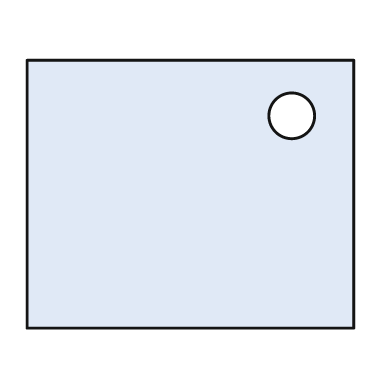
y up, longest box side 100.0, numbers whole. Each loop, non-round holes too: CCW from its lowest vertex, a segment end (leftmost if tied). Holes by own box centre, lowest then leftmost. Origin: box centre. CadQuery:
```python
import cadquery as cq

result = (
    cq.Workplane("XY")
    .moveTo(-50.0, -41.0)
    .lineTo(50.0, -41.0)
    .lineTo(50.0, 41.0)
    .lineTo(-50.0, 41.0)
    .close()
    .moveTo(31.0, 24.0)
    .circle(7.0)
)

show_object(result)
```